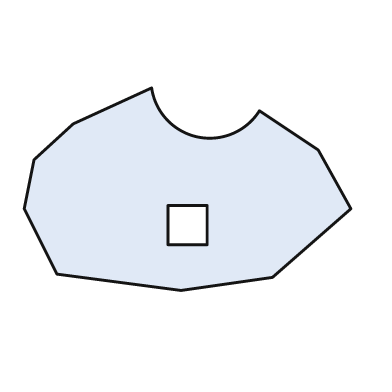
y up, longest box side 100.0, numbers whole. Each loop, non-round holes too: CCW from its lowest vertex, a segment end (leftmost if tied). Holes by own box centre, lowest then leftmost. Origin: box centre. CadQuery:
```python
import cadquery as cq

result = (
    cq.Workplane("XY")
    .moveTo(-2.0, -31.0)
    .lineTo(26.0, -27.0)
    .lineTo(50.0, -6.0)
    .lineTo(40.0, 12.0)
    .lineTo(22.0, 24.0)
    .threePointArc((3.0, 16.0), (-11.0, 31.0))
    .lineTo(-35.0, 20.0)
    .lineTo(-47.0, 9.0)
    .lineTo(-50.0, -6.0)
    .lineTo(-40.0, -26.0)
    .close()
    .moveTo(-6.0, -17.0)
    .lineTo(6.0, -17.0)
    .lineTo(6.0, -5.0)
    .lineTo(-6.0, -5.0)
    .close()
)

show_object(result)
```